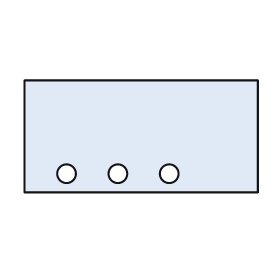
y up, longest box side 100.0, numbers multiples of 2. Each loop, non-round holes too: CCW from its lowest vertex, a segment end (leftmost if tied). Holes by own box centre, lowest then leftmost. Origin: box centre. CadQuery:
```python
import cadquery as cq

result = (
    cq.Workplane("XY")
    .moveTo(-50.0, -24.0)
    .lineTo(50.0, -24.0)
    .lineTo(50.0, 24.0)
    .lineTo(-50.0, 24.0)
    .close()
    .moveTo(-32.0, -16.0)
    .circle(4.0)
    .moveTo(-10.0, -16.0)
    .circle(4.0)
    .moveTo(12.0, -16.0)
    .circle(4.0)
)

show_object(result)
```